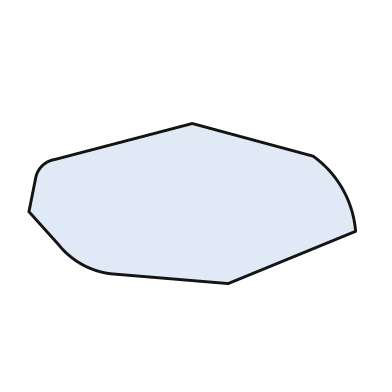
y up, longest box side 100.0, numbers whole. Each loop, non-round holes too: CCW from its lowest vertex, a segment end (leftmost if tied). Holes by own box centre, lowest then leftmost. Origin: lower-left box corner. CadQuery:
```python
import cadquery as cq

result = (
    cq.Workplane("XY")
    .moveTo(61.0, 0.0)
    .lineTo(100.0, 16.0)
    .threePointArc((96.0, 29.0), (87.0, 39.0))
    .lineTo(50.0, 49.0)
    .lineTo(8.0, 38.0)
    .threePointArc((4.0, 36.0), (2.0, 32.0))
    .lineTo(0.0, 22.0)
    .lineTo(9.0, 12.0)
    .threePointArc((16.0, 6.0), (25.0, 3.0))
    .close()
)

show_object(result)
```